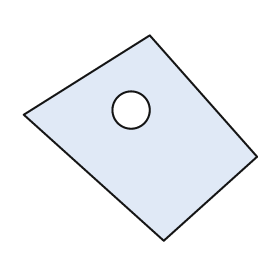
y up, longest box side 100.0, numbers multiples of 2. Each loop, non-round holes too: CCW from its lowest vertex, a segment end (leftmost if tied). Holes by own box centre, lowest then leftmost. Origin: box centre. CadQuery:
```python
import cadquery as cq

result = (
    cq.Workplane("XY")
    .moveTo(10.0, -44.0)
    .lineTo(50.0, -8.0)
    .lineTo(4.0, 44.0)
    .lineTo(-50.0, 10.0)
    .close()
    .moveTo(-4.0, 12.0)
    .circle(8.0)
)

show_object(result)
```